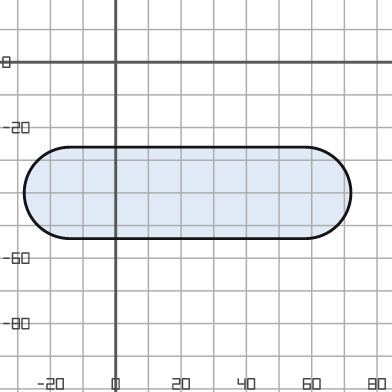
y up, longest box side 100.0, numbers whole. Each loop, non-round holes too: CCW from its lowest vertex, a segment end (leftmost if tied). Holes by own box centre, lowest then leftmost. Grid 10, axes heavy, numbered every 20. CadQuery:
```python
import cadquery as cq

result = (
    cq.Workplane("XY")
    .moveTo(-14.0, -54.0)
    .lineTo(58.0, -54.0)
    .threePointArc((72.0, -40.0), (58.0, -26.0))
    .lineTo(-14.0, -26.0)
    .threePointArc((-28.0, -40.0), (-14.0, -54.0))
    .close()
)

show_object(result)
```